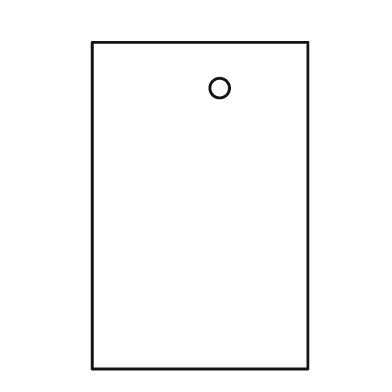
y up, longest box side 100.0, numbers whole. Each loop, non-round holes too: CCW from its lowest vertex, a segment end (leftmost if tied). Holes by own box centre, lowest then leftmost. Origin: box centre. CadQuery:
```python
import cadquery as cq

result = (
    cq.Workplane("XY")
    .moveTo(-33.0, -50.0)
    .lineTo(33.0, -50.0)
    .lineTo(33.0, 50.0)
    .lineTo(-33.0, 50.0)
    .close()
    .moveTo(6.0, 36.0)
    .circle(3.0)
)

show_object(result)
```